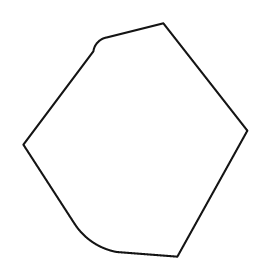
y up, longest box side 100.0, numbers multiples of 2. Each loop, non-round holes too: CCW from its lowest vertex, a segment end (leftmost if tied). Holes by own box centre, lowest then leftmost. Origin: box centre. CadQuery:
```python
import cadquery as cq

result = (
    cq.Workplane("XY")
    .moveTo(18.0, -50.0)
    .lineTo(48.0, 4.0)
    .lineTo(12.0, 50.0)
    .lineTo(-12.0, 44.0)
    .threePointArc((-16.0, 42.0), (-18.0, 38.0))
    .lineTo(-48.0, -2.0)
    .lineTo(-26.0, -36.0)
    .threePointArc((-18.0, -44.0), (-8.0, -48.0))
    .close()
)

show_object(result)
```